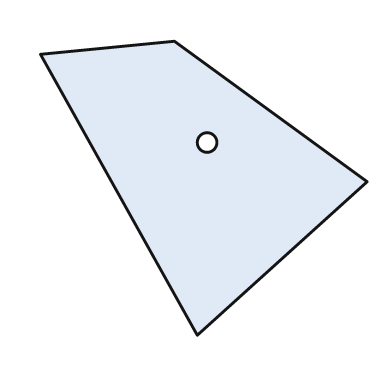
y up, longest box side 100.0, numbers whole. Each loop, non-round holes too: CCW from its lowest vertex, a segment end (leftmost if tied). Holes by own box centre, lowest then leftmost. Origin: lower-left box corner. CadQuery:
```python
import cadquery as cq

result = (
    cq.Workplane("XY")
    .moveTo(48.0, 0.0)
    .lineTo(100.0, 47.0)
    .lineTo(41.0, 90.0)
    .lineTo(0.0, 86.0)
    .close()
    .moveTo(51.0, 59.0)
    .circle(3.0)
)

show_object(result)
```